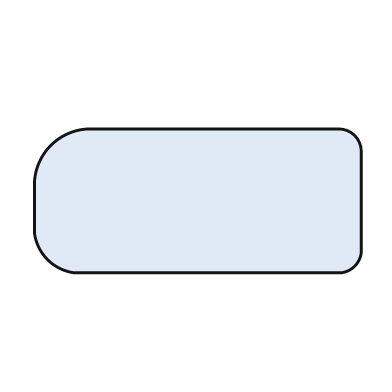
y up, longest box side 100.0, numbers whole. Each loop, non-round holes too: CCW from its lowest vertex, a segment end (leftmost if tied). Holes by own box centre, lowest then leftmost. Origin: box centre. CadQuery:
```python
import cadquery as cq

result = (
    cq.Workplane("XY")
    .moveTo(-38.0, -22.0)
    .lineTo(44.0, -22.0)
    .threePointArc((48.0, -20.0), (50.0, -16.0))
    .lineTo(50.0, 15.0)
    .threePointArc((48.0, 20.0), (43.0, 22.0))
    .lineTo(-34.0, 22.0)
    .threePointArc((-45.0, 17.0), (-50.0, 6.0))
    .lineTo(-50.0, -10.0)
    .threePointArc((-46.0, -18.0), (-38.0, -22.0))
    .close()
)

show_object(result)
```